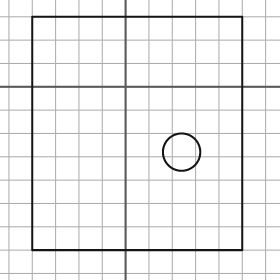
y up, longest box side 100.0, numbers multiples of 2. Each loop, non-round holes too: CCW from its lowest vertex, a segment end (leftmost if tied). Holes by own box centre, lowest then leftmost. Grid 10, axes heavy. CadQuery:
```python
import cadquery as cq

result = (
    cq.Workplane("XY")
    .moveTo(-40.0, -70.0)
    .lineTo(50.0, -70.0)
    .lineTo(50.0, 30.0)
    .lineTo(-40.0, 30.0)
    .close()
    .moveTo(24.0, -28.0)
    .circle(8.0)
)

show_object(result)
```